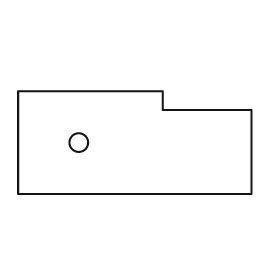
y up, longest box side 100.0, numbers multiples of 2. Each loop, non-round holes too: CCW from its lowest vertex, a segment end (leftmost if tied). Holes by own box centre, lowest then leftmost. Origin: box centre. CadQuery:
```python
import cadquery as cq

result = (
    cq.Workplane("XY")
    .moveTo(-50.0, -22.0)
    .lineTo(50.0, -22.0)
    .lineTo(50.0, 14.0)
    .lineTo(12.0, 14.0)
    .lineTo(12.0, 22.0)
    .lineTo(-50.0, 22.0)
    .close()
    .moveTo(-24.0, 0.0)
    .circle(4.0)
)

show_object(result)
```